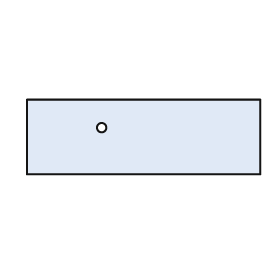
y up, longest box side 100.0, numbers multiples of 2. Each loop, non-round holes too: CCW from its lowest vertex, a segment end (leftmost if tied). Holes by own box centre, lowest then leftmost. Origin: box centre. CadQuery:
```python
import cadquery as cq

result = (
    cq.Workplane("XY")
    .moveTo(-50.0, -16.0)
    .lineTo(50.0, -16.0)
    .lineTo(50.0, 16.0)
    .lineTo(-50.0, 16.0)
    .close()
    .moveTo(-18.0, 4.0)
    .circle(2.0)
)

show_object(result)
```